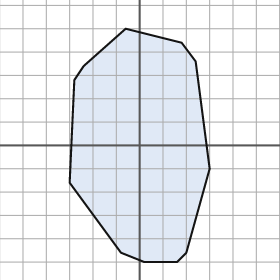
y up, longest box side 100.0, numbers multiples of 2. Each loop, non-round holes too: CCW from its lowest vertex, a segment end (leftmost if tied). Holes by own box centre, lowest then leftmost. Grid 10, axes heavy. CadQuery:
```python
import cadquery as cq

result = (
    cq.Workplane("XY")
    .moveTo(2.0, -50.0)
    .lineTo(16.0, -50.0)
    .lineTo(20.0, -46.0)
    .lineTo(30.0, -10.0)
    .lineTo(24.0, 36.0)
    .lineTo(18.0, 44.0)
    .lineTo(-6.0, 50.0)
    .lineTo(-24.0, 34.0)
    .lineTo(-28.0, 28.0)
    .lineTo(-30.0, -16.0)
    .lineTo(-8.0, -46.0)
    .close()
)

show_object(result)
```